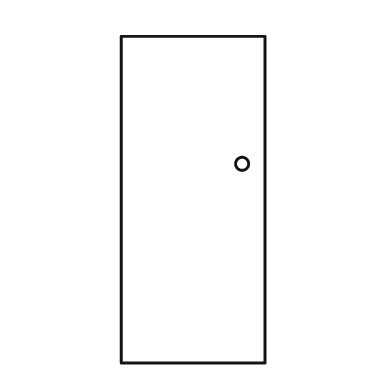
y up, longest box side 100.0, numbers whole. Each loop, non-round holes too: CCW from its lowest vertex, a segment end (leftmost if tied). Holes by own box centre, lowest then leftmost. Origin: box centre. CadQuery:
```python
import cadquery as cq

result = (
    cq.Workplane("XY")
    .moveTo(-22.0, -50.0)
    .lineTo(22.0, -50.0)
    .lineTo(22.0, 50.0)
    .lineTo(-22.0, 50.0)
    .close()
    .moveTo(15.0, 11.0)
    .circle(2.0)
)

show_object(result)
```